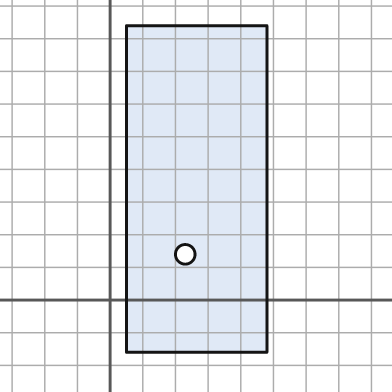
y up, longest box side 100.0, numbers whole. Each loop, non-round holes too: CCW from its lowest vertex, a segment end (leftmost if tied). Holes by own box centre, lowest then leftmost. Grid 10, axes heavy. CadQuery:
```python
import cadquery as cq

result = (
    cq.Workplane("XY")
    .moveTo(5.0, -16.0)
    .lineTo(48.0, -16.0)
    .lineTo(48.0, 84.0)
    .lineTo(5.0, 84.0)
    .close()
    .moveTo(23.0, 14.0)
    .circle(3.0)
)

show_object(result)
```